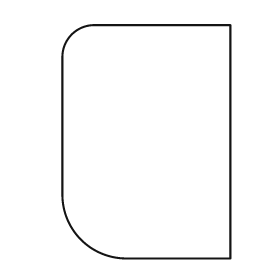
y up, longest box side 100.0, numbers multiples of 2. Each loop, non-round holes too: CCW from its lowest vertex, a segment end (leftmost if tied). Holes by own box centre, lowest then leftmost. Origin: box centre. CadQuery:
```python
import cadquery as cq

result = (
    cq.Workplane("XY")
    .moveTo(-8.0, -50.0)
    .lineTo(36.0, -50.0)
    .lineTo(36.0, 50.0)
    .lineTo(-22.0, 50.0)
    .threePointArc((-32.0, 46.0), (-36.0, 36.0))
    .lineTo(-36.0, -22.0)
    .threePointArc((-28.0, -42.0), (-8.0, -50.0))
    .close()
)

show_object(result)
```